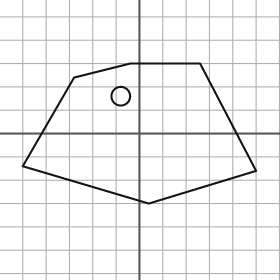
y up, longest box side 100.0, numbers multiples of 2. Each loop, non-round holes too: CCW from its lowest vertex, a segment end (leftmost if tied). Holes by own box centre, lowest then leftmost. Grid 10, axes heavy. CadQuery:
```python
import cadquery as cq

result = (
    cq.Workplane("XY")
    .moveTo(4.0, -30.0)
    .lineTo(50.0, -16.0)
    .lineTo(26.0, 30.0)
    .lineTo(-4.0, 30.0)
    .lineTo(-28.0, 24.0)
    .lineTo(-50.0, -14.0)
    .close()
    .moveTo(-8.0, 16.0)
    .circle(4.0)
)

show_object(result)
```